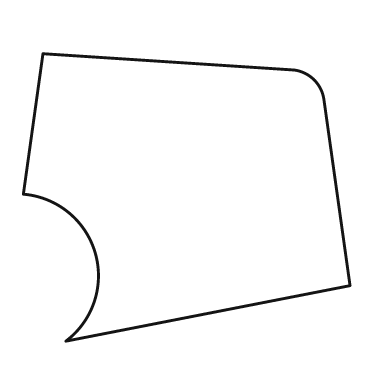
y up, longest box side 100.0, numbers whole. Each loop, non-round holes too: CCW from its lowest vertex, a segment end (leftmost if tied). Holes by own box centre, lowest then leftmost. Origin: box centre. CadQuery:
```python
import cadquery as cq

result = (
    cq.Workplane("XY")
    .moveTo(-37.0, -44.0)
    .lineTo(50.0, -27.0)
    .lineTo(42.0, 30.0)
    .threePointArc((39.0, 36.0), (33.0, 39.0))
    .lineTo(-44.0, 44.0)
    .lineTo(-50.0, 1.0)
    .threePointArc((-28.0, -17.0), (-37.0, -44.0))
    .close()
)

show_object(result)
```